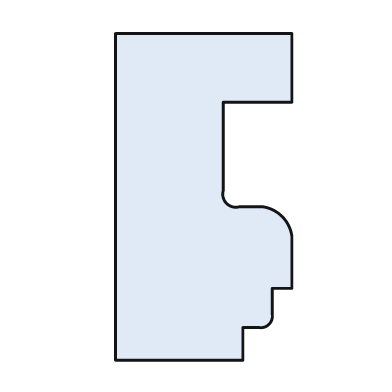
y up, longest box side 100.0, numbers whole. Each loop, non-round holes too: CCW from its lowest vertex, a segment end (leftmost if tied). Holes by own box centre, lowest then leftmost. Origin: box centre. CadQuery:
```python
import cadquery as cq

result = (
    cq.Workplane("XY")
    .moveTo(-27.0, -50.0)
    .lineTo(12.0, -50.0)
    .lineTo(12.0, -40.0)
    .lineTo(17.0, -40.0)
    .threePointArc((20.0, -39.0), (21.0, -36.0))
    .lineTo(21.0, -28.0)
    .lineTo(27.0, -28.0)
    .lineTo(27.0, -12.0)
    .threePointArc((24.0, -6.0), (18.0, -3.0))
    .lineTo(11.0, -3.0)
    .threePointArc((7.0, -2.0), (6.0, 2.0))
    .lineTo(6.0, 29.0)
    .lineTo(27.0, 29.0)
    .lineTo(27.0, 50.0)
    .lineTo(-27.0, 50.0)
    .close()
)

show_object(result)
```